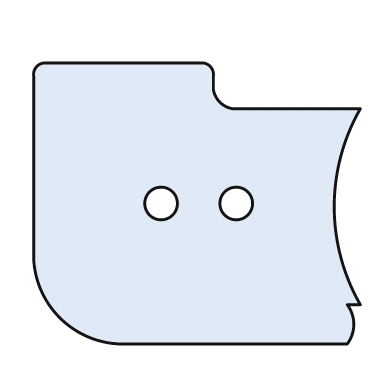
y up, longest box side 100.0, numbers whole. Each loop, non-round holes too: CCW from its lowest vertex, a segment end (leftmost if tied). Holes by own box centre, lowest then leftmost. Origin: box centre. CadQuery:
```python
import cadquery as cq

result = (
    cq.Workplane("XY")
    .moveTo(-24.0, -43.0)
    .lineTo(46.0, -43.0)
    .threePointArc((48.0, -37.0), (46.0, -31.0))
    .lineTo(50.0, -31.0)
    .threePointArc((42.0, -1.0), (50.0, 29.0))
    .lineTo(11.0, 29.0)
    .threePointArc((7.0, 31.0), (5.0, 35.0))
    .lineTo(5.0, 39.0)
    .threePointArc((4.0, 42.0), (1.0, 43.0))
    .lineTo(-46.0, 43.0)
    .threePointArc((-49.0, 42.0), (-50.0, 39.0))
    .lineTo(-50.0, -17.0)
    .threePointArc((-42.0, -35.0), (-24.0, -43.0))
    .close()
    .moveTo(-11.0, 0.0)
    .circle(5.0)
    .moveTo(12.0, 0.0)
    .circle(5.0)
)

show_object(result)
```